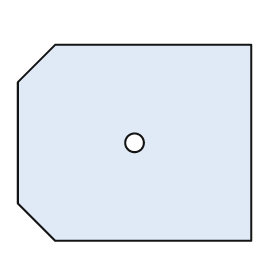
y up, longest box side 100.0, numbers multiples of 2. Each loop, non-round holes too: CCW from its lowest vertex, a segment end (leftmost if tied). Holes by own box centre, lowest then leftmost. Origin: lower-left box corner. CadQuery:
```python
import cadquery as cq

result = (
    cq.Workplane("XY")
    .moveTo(16.0, 0.0)
    .lineTo(100.0, 0.0)
    .lineTo(100.0, 84.0)
    .lineTo(16.0, 84.0)
    .lineTo(0.0, 68.0)
    .lineTo(0.0, 16.0)
    .close()
    .moveTo(50.0, 42.0)
    .circle(4.0)
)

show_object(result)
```